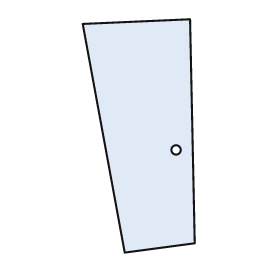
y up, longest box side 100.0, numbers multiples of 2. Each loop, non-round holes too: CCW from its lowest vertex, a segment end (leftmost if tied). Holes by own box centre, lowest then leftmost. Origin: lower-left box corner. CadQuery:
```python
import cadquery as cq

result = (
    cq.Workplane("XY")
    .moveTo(18.0, 0.0)
    .lineTo(48.0, 4.0)
    .lineTo(46.0, 100.0)
    .lineTo(0.0, 98.0)
    .close()
    .moveTo(40.0, 44.0)
    .circle(2.0)
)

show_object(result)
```